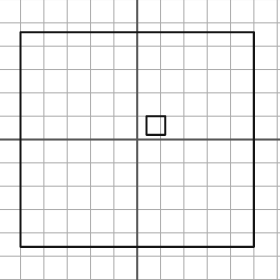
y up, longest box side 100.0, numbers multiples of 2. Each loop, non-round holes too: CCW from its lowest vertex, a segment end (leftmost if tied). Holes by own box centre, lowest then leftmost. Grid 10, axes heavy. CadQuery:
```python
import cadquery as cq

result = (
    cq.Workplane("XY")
    .moveTo(-50.0, -46.0)
    .lineTo(50.0, -46.0)
    .lineTo(50.0, 46.0)
    .lineTo(-50.0, 46.0)
    .close()
    .moveTo(4.0, 2.0)
    .lineTo(12.0, 2.0)
    .lineTo(12.0, 10.0)
    .lineTo(4.0, 10.0)
    .close()
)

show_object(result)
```